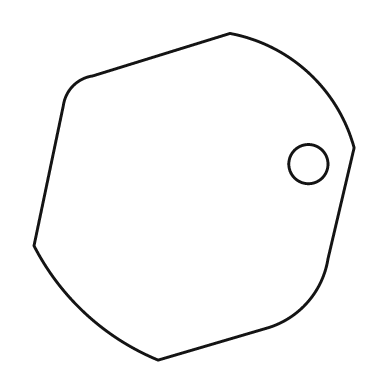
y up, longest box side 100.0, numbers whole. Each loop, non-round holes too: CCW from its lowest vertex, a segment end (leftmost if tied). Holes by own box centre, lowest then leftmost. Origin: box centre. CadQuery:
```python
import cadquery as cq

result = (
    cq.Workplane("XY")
    .moveTo(-11.0, -50.0)
    .lineTo(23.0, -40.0)
    .threePointArc((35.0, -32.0), (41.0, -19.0))
    .lineTo(49.0, 15.0)
    .threePointArc((35.0, 38.0), (11.0, 50.0))
    .lineTo(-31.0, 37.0)
    .threePointArc((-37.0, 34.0), (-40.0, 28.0))
    .lineTo(-49.0, -15.0)
    .threePointArc((-33.0, -36.0), (-11.0, -50.0))
    .close()
    .moveTo(35.0, 10.0)
    .circle(6.0)
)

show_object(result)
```